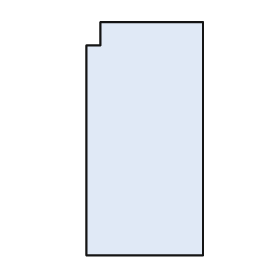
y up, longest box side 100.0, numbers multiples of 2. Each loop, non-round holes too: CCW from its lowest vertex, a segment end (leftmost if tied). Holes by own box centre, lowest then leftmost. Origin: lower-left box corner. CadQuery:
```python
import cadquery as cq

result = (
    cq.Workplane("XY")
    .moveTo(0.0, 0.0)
    .lineTo(50.0, 0.0)
    .lineTo(50.0, 100.0)
    .lineTo(6.0, 100.0)
    .lineTo(6.0, 90.0)
    .lineTo(0.0, 90.0)
    .close()
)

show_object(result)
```